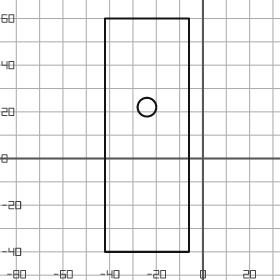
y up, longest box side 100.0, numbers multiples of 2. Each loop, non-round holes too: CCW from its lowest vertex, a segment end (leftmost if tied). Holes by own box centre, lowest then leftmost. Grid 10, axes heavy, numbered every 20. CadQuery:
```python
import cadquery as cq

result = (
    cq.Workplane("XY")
    .moveTo(-42.0, -40.0)
    .lineTo(-6.0, -40.0)
    .lineTo(-6.0, 60.0)
    .lineTo(-42.0, 60.0)
    .close()
    .moveTo(-24.0, 22.0)
    .circle(4.0)
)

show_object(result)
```